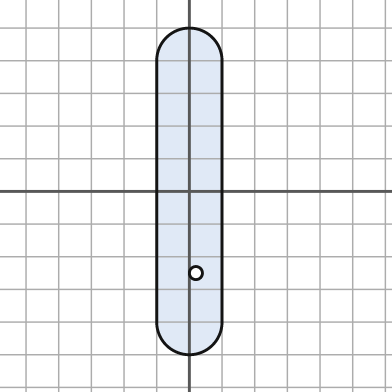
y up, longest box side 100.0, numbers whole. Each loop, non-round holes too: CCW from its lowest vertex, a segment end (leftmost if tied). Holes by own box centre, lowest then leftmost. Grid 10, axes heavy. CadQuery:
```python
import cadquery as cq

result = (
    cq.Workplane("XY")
    .moveTo(-10.0, -40.0)
    .threePointArc((0.0, -50.0), (10.0, -40.0))
    .lineTo(10.0, 40.0)
    .threePointArc((0.0, 50.0), (-10.0, 40.0))
    .close()
    .moveTo(2.0, -25.0)
    .circle(2.0)
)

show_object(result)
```